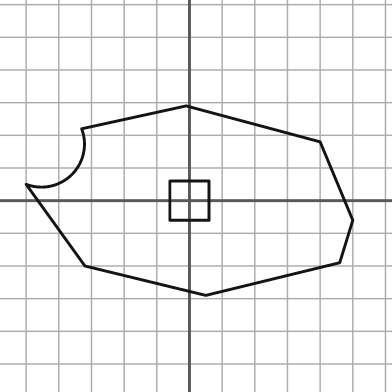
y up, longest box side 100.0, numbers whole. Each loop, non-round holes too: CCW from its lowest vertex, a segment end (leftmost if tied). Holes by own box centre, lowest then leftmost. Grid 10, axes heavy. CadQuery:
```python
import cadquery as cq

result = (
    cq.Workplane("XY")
    .moveTo(5.0, -29.0)
    .lineTo(46.0, -19.0)
    .lineTo(50.0, -6.0)
    .lineTo(40.0, 18.0)
    .lineTo(-1.0, 29.0)
    .lineTo(-33.0, 22.0)
    .threePointArc((-36.0, 8.0), (-50.0, 5.0))
    .lineTo(-32.0, -20.0)
    .close()
    .moveTo(-6.0, -6.0)
    .lineTo(6.0, -6.0)
    .lineTo(6.0, 6.0)
    .lineTo(-6.0, 6.0)
    .close()
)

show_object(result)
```